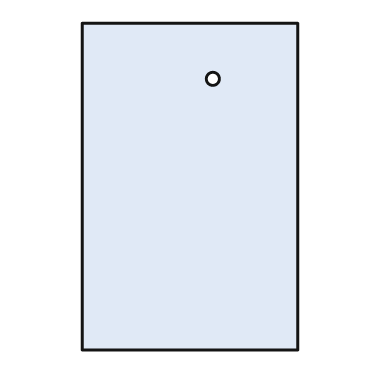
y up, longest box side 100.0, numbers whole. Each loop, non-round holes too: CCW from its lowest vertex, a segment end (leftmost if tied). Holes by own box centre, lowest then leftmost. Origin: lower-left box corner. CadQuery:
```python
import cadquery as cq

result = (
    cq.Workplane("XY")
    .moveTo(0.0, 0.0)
    .lineTo(66.0, 0.0)
    .lineTo(66.0, 100.0)
    .lineTo(0.0, 100.0)
    .close()
    .moveTo(40.0, 83.0)
    .circle(2.0)
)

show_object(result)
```